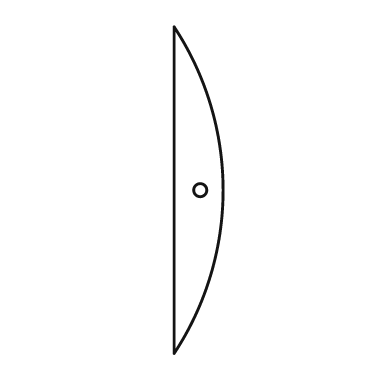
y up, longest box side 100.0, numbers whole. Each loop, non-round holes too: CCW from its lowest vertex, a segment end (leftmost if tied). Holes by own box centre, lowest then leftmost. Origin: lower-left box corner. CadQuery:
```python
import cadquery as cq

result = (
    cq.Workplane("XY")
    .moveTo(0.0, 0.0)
    .threePointArc((15.0, 50.0), (0.0, 100.0))
    .close()
    .moveTo(8.0, 50.0)
    .circle(2.0)
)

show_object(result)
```